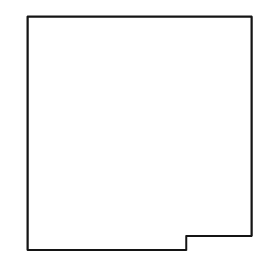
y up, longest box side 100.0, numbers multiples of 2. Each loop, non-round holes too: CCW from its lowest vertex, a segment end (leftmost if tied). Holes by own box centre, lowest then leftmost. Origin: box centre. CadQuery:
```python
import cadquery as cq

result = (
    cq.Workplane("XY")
    .moveTo(-48.0, -50.0)
    .lineTo(20.0, -50.0)
    .lineTo(20.0, -44.0)
    .lineTo(48.0, -44.0)
    .lineTo(48.0, 50.0)
    .lineTo(-48.0, 50.0)
    .close()
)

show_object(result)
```